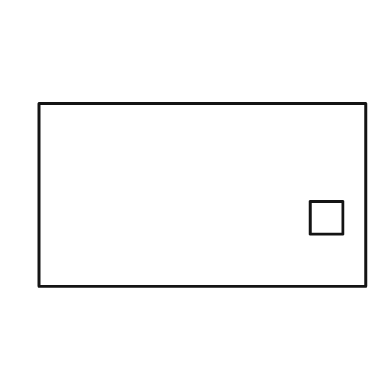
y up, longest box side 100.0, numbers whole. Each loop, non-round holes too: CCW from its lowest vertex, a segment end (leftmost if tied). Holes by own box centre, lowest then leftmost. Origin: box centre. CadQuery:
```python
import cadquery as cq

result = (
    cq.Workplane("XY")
    .moveTo(-50.0, -28.0)
    .lineTo(50.0, -28.0)
    .lineTo(50.0, 28.0)
    .lineTo(-50.0, 28.0)
    .close()
    .moveTo(33.0, -12.0)
    .lineTo(43.0, -12.0)
    .lineTo(43.0, -2.0)
    .lineTo(33.0, -2.0)
    .close()
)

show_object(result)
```